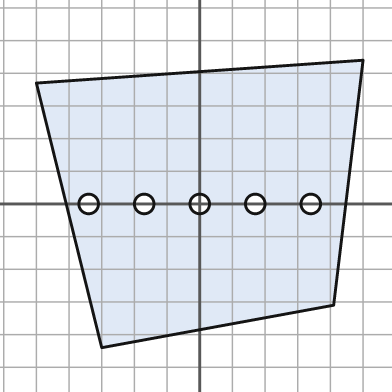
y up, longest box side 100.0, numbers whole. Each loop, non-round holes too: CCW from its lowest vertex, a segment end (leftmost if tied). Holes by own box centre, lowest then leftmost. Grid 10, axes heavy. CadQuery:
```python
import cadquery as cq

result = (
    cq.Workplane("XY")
    .moveTo(-30.0, -44.0)
    .lineTo(41.0, -31.0)
    .lineTo(50.0, 44.0)
    .lineTo(-50.0, 37.0)
    .close()
    .moveTo(-34.0, 0.0)
    .circle(3.0)
    .moveTo(-17.0, 0.0)
    .circle(3.0)
    .moveTo(0.0, 0.0)
    .circle(3.0)
    .moveTo(17.0, 0.0)
    .circle(3.0)
    .moveTo(34.0, 0.0)
    .circle(3.0)
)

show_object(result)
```